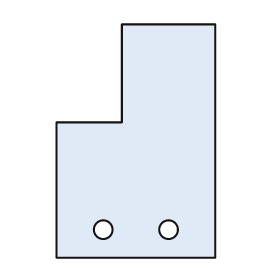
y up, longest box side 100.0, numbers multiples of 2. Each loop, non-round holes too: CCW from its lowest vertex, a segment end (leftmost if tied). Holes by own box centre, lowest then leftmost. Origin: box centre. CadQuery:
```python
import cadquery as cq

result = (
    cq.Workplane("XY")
    .moveTo(-34.0, -50.0)
    .lineTo(34.0, -50.0)
    .lineTo(34.0, 50.0)
    .lineTo(-6.0, 50.0)
    .lineTo(-6.0, 8.0)
    .lineTo(-34.0, 8.0)
    .close()
    .moveTo(-14.0, -38.0)
    .circle(4.0)
    .moveTo(14.0, -38.0)
    .circle(4.0)
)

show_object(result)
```